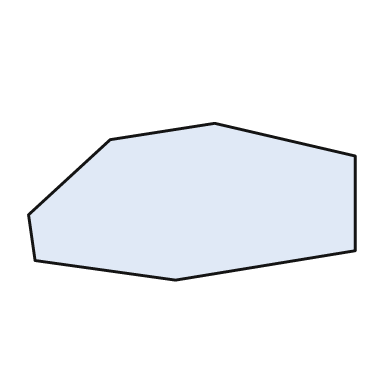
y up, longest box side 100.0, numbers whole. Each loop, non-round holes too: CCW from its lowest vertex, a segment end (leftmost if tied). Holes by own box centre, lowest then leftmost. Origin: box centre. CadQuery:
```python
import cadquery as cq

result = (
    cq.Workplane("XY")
    .moveTo(-5.0, -24.0)
    .lineTo(50.0, -15.0)
    .lineTo(50.0, 14.0)
    .lineTo(7.0, 24.0)
    .lineTo(-25.0, 19.0)
    .lineTo(-50.0, -4.0)
    .lineTo(-48.0, -18.0)
    .close()
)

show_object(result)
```